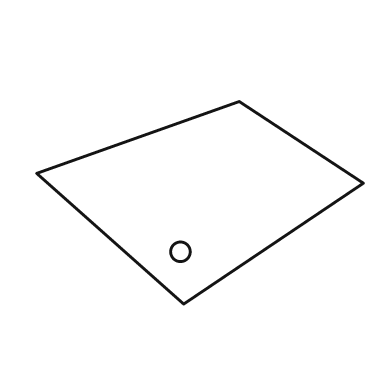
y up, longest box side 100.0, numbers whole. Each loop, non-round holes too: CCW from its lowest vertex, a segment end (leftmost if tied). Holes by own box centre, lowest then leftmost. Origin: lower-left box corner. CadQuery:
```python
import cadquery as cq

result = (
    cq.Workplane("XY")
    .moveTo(45.0, 0.0)
    .lineTo(100.0, 37.0)
    .lineTo(62.0, 62.0)
    .lineTo(0.0, 40.0)
    .close()
    .moveTo(44.0, 16.0)
    .circle(3.0)
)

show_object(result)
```